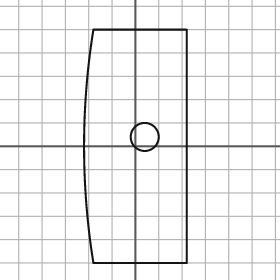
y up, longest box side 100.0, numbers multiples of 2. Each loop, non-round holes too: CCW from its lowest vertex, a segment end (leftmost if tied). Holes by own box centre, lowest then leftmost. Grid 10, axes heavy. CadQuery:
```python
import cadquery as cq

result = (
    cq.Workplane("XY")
    .moveTo(-18.0, -50.0)
    .lineTo(22.0, -50.0)
    .lineTo(22.0, 50.0)
    .lineTo(-18.0, 50.0)
    .threePointArc((-22.0, 0.0), (-18.0, -50.0))
    .close()
    .moveTo(4.0, 4.0)
    .circle(6.0)
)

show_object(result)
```